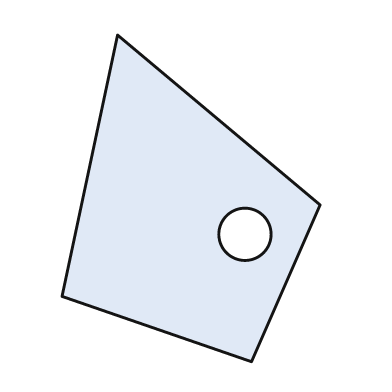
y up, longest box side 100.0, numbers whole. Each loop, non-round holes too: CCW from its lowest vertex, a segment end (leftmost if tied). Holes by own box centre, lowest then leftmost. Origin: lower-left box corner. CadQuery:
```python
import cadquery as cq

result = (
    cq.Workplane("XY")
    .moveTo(58.0, 0.0)
    .lineTo(79.0, 48.0)
    .lineTo(17.0, 100.0)
    .lineTo(0.0, 20.0)
    .close()
    .moveTo(56.0, 39.0)
    .circle(8.0)
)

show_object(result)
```